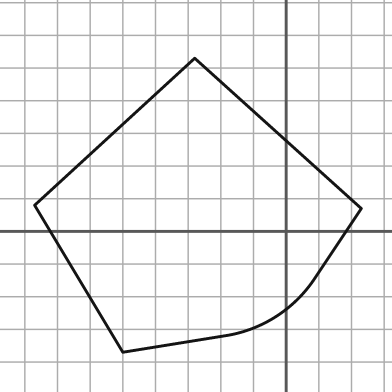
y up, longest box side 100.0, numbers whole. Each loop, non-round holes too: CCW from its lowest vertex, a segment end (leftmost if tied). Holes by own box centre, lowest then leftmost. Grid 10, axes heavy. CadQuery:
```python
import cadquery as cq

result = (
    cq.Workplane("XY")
    .moveTo(-50.0, -37.0)
    .lineTo(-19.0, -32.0)
    .threePointArc((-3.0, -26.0), (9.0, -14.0))
    .lineTo(23.0, 7.0)
    .lineTo(-28.0, 53.0)
    .lineTo(-77.0, 8.0)
    .close()
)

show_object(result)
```